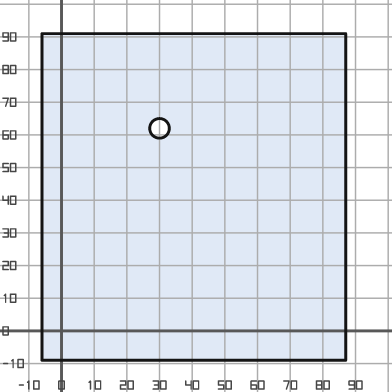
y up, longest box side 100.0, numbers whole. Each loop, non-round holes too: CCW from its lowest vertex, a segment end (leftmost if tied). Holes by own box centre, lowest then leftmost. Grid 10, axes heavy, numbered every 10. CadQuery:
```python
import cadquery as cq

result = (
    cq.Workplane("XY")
    .moveTo(-6.0, -9.0)
    .lineTo(87.0, -9.0)
    .lineTo(87.0, 91.0)
    .lineTo(-6.0, 91.0)
    .close()
    .moveTo(30.0, 62.0)
    .circle(3.0)
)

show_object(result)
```